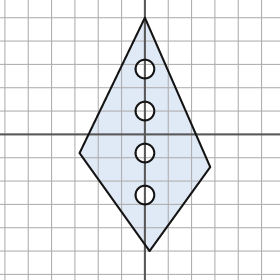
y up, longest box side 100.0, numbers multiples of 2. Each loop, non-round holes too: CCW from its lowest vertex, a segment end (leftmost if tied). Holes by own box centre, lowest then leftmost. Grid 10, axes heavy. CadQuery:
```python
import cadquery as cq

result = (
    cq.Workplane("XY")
    .moveTo(2.0, -50.0)
    .lineTo(28.0, -14.0)
    .lineTo(0.0, 50.0)
    .lineTo(-28.0, -8.0)
    .close()
    .moveTo(0.0, -26.0)
    .circle(4.0)
    .moveTo(0.0, -8.0)
    .circle(4.0)
    .moveTo(0.0, 10.0)
    .circle(4.0)
    .moveTo(0.0, 28.0)
    .circle(4.0)
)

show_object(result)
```